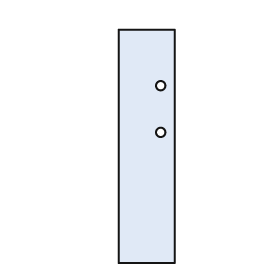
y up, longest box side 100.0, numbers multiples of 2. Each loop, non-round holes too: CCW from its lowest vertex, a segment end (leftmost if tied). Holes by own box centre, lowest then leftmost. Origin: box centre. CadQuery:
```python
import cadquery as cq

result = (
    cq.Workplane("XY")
    .moveTo(-12.0, -50.0)
    .lineTo(12.0, -50.0)
    .lineTo(12.0, 50.0)
    .lineTo(-12.0, 50.0)
    .close()
    .moveTo(6.0, 6.0)
    .circle(2.0)
    .moveTo(6.0, 26.0)
    .circle(2.0)
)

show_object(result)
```